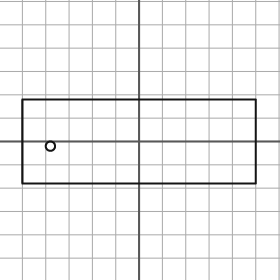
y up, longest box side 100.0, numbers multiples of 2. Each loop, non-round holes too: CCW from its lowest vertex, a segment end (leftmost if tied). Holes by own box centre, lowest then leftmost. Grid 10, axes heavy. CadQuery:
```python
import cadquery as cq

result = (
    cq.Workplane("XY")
    .moveTo(-50.0, -18.0)
    .lineTo(50.0, -18.0)
    .lineTo(50.0, 18.0)
    .lineTo(-50.0, 18.0)
    .close()
    .moveTo(-38.0, -2.0)
    .circle(2.0)
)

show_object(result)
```